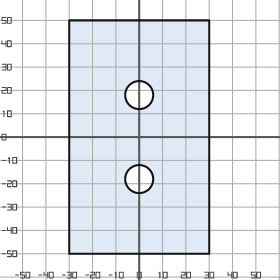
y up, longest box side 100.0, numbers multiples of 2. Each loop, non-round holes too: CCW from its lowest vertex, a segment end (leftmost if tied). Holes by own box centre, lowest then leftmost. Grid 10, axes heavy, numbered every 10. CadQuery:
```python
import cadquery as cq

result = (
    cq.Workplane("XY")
    .moveTo(-30.0, -50.0)
    .lineTo(30.0, -50.0)
    .lineTo(30.0, 50.0)
    .lineTo(-30.0, 50.0)
    .close()
    .moveTo(0.0, -18.0)
    .circle(6.0)
    .moveTo(0.0, 18.0)
    .circle(6.0)
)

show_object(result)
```